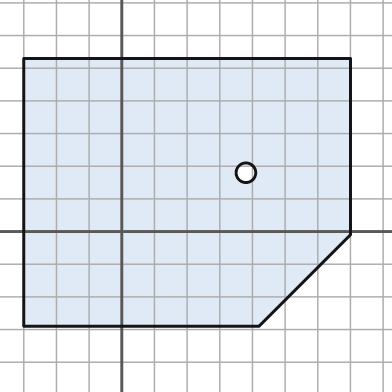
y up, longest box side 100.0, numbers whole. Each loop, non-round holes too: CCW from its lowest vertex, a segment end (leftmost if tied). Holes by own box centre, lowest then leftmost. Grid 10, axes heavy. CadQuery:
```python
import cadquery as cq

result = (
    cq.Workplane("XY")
    .moveTo(-30.0, -29.0)
    .lineTo(42.0, -29.0)
    .lineTo(70.0, -1.0)
    .lineTo(70.0, 53.0)
    .lineTo(-30.0, 53.0)
    .close()
    .moveTo(38.0, 18.0)
    .circle(3.0)
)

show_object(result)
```